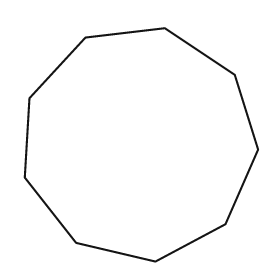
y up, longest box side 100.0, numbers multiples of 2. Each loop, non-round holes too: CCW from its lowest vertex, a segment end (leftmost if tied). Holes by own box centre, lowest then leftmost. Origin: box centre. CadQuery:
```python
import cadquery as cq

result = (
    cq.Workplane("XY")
    .moveTo(6.0, -50.0)
    .lineTo(36.0, -34.0)
    .lineTo(50.0, -2.0)
    .lineTo(40.0, 30.0)
    .lineTo(10.0, 50.0)
    .lineTo(-24.0, 46.0)
    .lineTo(-48.0, 20.0)
    .lineTo(-50.0, -14.0)
    .lineTo(-28.0, -42.0)
    .close()
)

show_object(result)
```